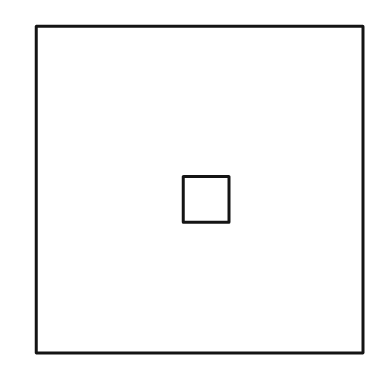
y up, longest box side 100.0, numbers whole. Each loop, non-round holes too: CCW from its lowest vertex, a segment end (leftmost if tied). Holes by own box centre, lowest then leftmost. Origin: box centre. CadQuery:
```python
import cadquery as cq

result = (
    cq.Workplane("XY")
    .moveTo(-50.0, -50.0)
    .lineTo(50.0, -50.0)
    .lineTo(50.0, 50.0)
    .lineTo(-50.0, 50.0)
    .close()
    .moveTo(-5.0, -10.0)
    .lineTo(9.0, -10.0)
    .lineTo(9.0, 4.0)
    .lineTo(-5.0, 4.0)
    .close()
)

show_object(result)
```